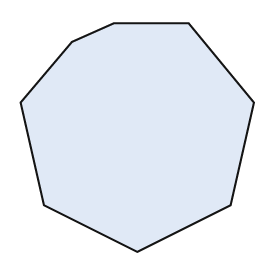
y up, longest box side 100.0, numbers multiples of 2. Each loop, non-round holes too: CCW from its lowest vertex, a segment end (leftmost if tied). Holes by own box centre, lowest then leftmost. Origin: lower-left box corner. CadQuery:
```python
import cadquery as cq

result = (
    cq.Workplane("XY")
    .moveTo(50.0, 0.0)
    .lineTo(90.0, 20.0)
    .lineTo(100.0, 64.0)
    .lineTo(72.0, 98.0)
    .lineTo(40.0, 98.0)
    .lineTo(22.0, 90.0)
    .lineTo(0.0, 64.0)
    .lineTo(10.0, 20.0)
    .close()
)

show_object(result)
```